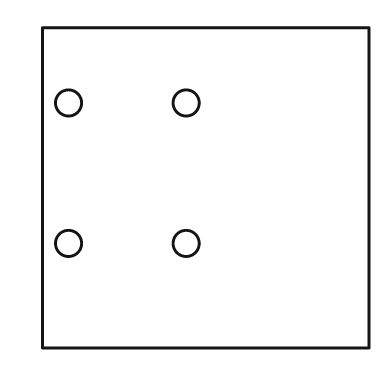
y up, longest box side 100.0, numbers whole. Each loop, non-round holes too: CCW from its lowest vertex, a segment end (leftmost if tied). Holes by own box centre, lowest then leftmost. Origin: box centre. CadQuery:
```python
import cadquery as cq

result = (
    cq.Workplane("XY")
    .moveTo(-50.0, -49.0)
    .lineTo(50.0, -49.0)
    .lineTo(50.0, 49.0)
    .lineTo(-50.0, 49.0)
    .close()
    .moveTo(-42.0, -17.0)
    .circle(4.0)
    .moveTo(-6.0, -17.0)
    .circle(4.0)
    .moveTo(-42.0, 26.0)
    .circle(4.0)
    .moveTo(-6.0, 26.0)
    .circle(4.0)
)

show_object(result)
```